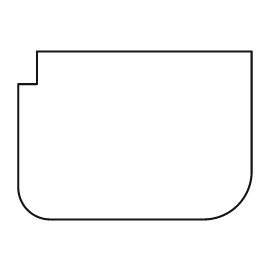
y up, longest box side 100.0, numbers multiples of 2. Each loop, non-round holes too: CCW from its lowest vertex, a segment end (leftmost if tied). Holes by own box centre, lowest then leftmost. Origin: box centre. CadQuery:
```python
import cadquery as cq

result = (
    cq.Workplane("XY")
    .moveTo(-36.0, -36.0)
    .lineTo(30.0, -36.0)
    .threePointArc((44.0, -30.0), (50.0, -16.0))
    .lineTo(50.0, 36.0)
    .lineTo(-42.0, 36.0)
    .lineTo(-42.0, 22.0)
    .lineTo(-50.0, 22.0)
    .lineTo(-50.0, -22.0)
    .threePointArc((-46.0, -32.0), (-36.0, -36.0))
    .close()
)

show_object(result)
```